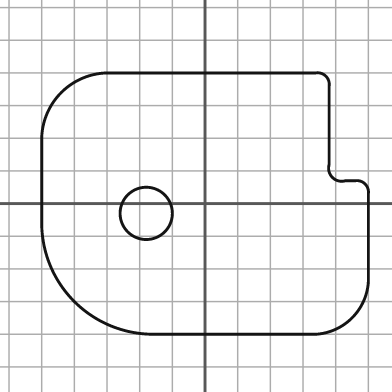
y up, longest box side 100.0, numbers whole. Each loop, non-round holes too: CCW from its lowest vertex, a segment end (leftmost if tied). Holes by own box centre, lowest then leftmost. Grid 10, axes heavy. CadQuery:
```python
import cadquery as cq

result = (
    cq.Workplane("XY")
    .moveTo(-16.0, -40.0)
    .lineTo(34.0, -40.0)
    .threePointArc((45.0, -35.0), (50.0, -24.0))
    .lineTo(50.0, 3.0)
    .threePointArc((49.0, 6.0), (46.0, 7.0))
    .lineTo(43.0, 7.0)
    .threePointArc((39.0, 8.0), (38.0, 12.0))
    .lineTo(38.0, 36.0)
    .threePointArc((37.0, 39.0), (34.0, 40.0))
    .lineTo(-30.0, 40.0)
    .threePointArc((-44.0, 34.0), (-50.0, 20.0))
    .lineTo(-50.0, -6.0)
    .threePointArc((-40.0, -30.0), (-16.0, -40.0))
    .close()
    .moveTo(-18.0, -3.0)
    .circle(8.0)
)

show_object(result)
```